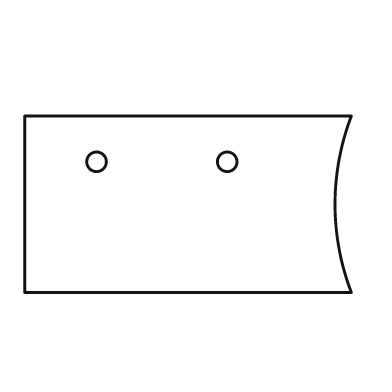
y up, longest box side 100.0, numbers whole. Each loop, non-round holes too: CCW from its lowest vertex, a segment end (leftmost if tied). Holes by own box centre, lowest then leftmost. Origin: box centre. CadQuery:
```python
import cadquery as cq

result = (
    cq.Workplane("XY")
    .moveTo(-50.0, -27.0)
    .lineTo(50.0, -27.0)
    .threePointArc((45.0, 0.0), (50.0, 27.0))
    .lineTo(-50.0, 27.0)
    .close()
    .moveTo(-28.0, 13.0)
    .circle(3.0)
    .moveTo(12.0, 13.0)
    .circle(3.0)
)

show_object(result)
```